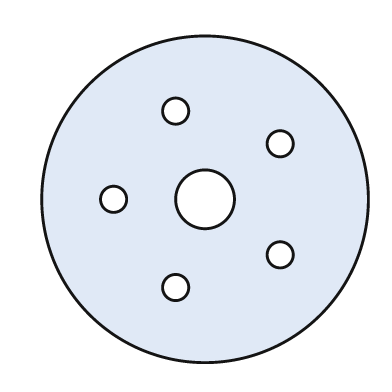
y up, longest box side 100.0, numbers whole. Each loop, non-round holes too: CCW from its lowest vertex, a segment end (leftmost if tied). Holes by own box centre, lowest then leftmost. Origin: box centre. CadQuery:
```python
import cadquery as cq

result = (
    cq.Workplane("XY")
    .moveTo(0.0, 0.0)
    .circle(50.0)
    .moveTo(-9.0, -27.0)
    .circle(4.0)
    .moveTo(23.0, -17.0)
    .circle(4.0)
    .moveTo(-28.0, 0.0)
    .circle(4.0)
    .moveTo(0.0, 0.0)
    .circle(9.0)
    .moveTo(23.0, 17.0)
    .circle(4.0)
    .moveTo(-9.0, 27.0)
    .circle(4.0)
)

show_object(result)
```